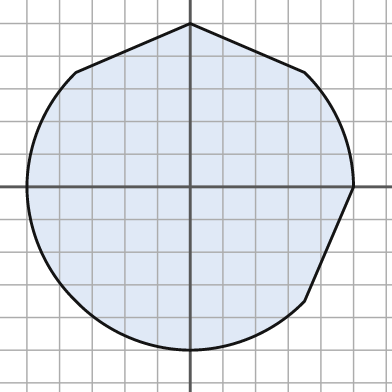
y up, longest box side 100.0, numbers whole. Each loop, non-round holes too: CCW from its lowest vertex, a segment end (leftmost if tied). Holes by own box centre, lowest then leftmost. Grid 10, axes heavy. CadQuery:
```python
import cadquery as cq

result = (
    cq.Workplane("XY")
    .moveTo(0.0, -50.0)
    .threePointArc((19.0, -46.0), (35.0, -35.0))
    .lineTo(50.0, 0.0)
    .threePointArc((46.0, 19.0), (35.0, 35.0))
    .lineTo(0.0, 50.0)
    .lineTo(-35.0, 35.0)
    .threePointArc((-46.0, 19.0), (-50.0, 0.0))
    .threePointArc((-46.0, -19.0), (-35.0, -35.0))
    .threePointArc((-19.0, -46.0), (0.0, -50.0))
    .close()
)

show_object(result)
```